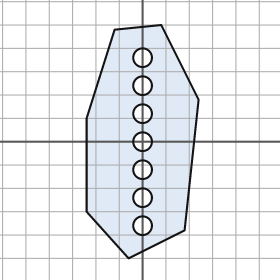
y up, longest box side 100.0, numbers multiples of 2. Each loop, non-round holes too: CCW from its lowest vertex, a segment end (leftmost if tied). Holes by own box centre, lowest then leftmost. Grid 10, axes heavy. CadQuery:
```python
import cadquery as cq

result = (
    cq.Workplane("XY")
    .moveTo(-6.0, -50.0)
    .lineTo(18.0, -38.0)
    .lineTo(24.0, 18.0)
    .lineTo(8.0, 50.0)
    .lineTo(-12.0, 48.0)
    .lineTo(-24.0, 10.0)
    .lineTo(-24.0, -30.0)
    .close()
    .moveTo(0.0, -36.0)
    .circle(4.0)
    .moveTo(0.0, -24.0)
    .circle(4.0)
    .moveTo(0.0, -12.0)
    .circle(4.0)
    .moveTo(0.0, 0.0)
    .circle(4.0)
    .moveTo(0.0, 12.0)
    .circle(4.0)
    .moveTo(0.0, 24.0)
    .circle(4.0)
    .moveTo(0.0, 36.0)
    .circle(4.0)
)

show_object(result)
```